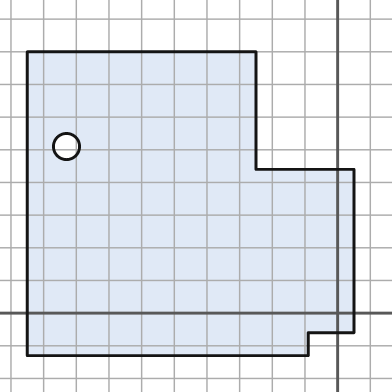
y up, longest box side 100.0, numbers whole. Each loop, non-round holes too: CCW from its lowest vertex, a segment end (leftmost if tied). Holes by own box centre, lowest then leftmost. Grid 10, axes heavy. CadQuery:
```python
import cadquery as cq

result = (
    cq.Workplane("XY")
    .moveTo(-95.0, -13.0)
    .lineTo(-9.0, -13.0)
    .lineTo(-9.0, -6.0)
    .lineTo(5.0, -6.0)
    .lineTo(5.0, 44.0)
    .lineTo(-25.0, 44.0)
    .lineTo(-25.0, 80.0)
    .lineTo(-95.0, 80.0)
    .close()
    .moveTo(-83.0, 51.0)
    .circle(4.0)
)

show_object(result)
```